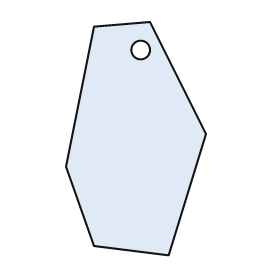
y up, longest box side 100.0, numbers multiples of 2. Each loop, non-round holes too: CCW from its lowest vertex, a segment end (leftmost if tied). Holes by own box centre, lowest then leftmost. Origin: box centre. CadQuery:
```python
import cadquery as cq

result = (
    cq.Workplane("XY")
    .moveTo(14.0, -50.0)
    .lineTo(30.0, 2.0)
    .lineTo(6.0, 50.0)
    .lineTo(-18.0, 48.0)
    .lineTo(-30.0, -12.0)
    .lineTo(-18.0, -46.0)
    .close()
    .moveTo(2.0, 38.0)
    .circle(4.0)
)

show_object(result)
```